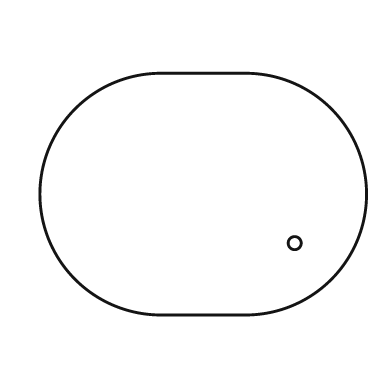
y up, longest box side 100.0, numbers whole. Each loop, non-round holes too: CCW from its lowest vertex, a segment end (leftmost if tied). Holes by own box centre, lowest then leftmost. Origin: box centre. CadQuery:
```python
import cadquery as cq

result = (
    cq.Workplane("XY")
    .moveTo(-13.0, -37.0)
    .lineTo(13.0, -37.0)
    .threePointArc((50.0, 0.0), (13.0, 37.0))
    .lineTo(-13.0, 37.0)
    .threePointArc((-50.0, 0.0), (-13.0, -37.0))
    .close()
    .moveTo(28.0, -15.0)
    .circle(2.0)
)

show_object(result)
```